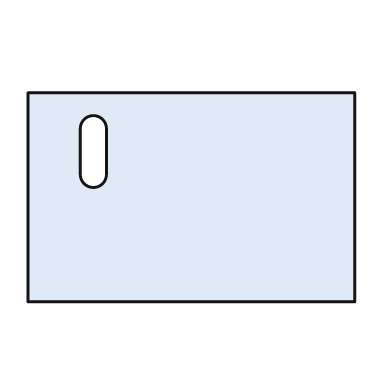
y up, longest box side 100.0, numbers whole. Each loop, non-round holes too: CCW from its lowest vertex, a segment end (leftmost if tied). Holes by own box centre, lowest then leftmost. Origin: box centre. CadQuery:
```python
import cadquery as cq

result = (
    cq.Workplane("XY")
    .moveTo(-50.0, -32.0)
    .lineTo(50.0, -32.0)
    .lineTo(50.0, 32.0)
    .lineTo(-50.0, 32.0)
    .close()
    .moveTo(-34.0, 7.0)
    .threePointArc((-30.0, 3.0), (-26.0, 7.0))
    .lineTo(-26.0, 21.0)
    .threePointArc((-30.0, 25.0), (-34.0, 21.0))
    .close()
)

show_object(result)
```